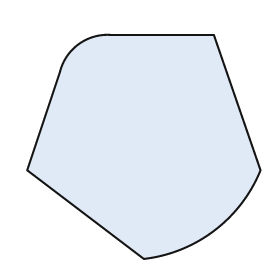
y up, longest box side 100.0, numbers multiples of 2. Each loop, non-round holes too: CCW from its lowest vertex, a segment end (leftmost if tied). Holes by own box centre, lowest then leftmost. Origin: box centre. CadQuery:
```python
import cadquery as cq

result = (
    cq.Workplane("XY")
    .moveTo(0.0, -48.0)
    .threePointArc((30.0, -36.0), (50.0, -10.0))
    .lineTo(30.0, 48.0)
    .lineTo(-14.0, 48.0)
    .threePointArc((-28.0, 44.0), (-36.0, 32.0))
    .lineTo(-50.0, -10.0)
    .close()
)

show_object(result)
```